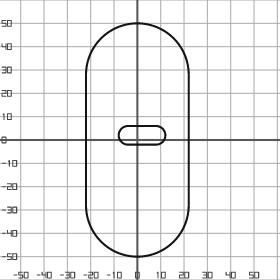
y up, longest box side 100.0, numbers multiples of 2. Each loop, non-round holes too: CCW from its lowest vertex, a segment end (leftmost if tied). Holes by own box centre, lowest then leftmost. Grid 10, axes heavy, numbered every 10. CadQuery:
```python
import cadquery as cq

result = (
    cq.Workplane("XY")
    .moveTo(-22.0, -28.0)
    .threePointArc((0.0, -50.0), (22.0, -28.0))
    .lineTo(22.0, 28.0)
    .threePointArc((0.0, 50.0), (-22.0, 28.0))
    .close()
    .moveTo(-4.0, -2.0)
    .lineTo(8.0, -2.0)
    .threePointArc((12.0, 2.0), (8.0, 6.0))
    .lineTo(-4.0, 6.0)
    .threePointArc((-8.0, 2.0), (-4.0, -2.0))
    .close()
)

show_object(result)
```